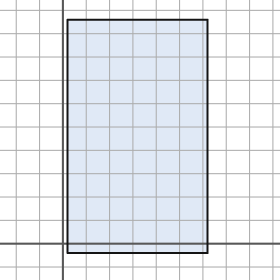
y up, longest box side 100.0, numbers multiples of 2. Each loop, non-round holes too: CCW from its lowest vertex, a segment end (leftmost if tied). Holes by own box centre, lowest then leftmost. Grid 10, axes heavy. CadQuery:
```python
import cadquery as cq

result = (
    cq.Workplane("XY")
    .moveTo(2.0, -4.0)
    .lineTo(62.0, -4.0)
    .lineTo(62.0, 96.0)
    .lineTo(2.0, 96.0)
    .close()
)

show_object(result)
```